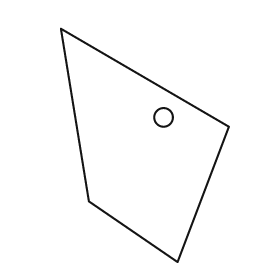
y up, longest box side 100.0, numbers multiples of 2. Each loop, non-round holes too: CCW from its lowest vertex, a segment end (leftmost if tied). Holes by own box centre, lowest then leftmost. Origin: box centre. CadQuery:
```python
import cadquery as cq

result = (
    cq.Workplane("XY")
    .moveTo(14.0, -50.0)
    .lineTo(36.0, 8.0)
    .lineTo(-36.0, 50.0)
    .lineTo(-24.0, -24.0)
    .close()
    .moveTo(8.0, 12.0)
    .circle(4.0)
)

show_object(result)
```